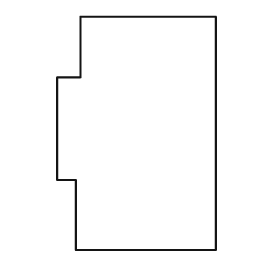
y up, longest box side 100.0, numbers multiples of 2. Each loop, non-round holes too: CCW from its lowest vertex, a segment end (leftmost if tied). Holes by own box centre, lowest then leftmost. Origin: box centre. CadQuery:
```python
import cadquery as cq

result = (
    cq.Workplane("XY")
    .moveTo(-26.0, -50.0)
    .lineTo(34.0, -50.0)
    .lineTo(34.0, 50.0)
    .lineTo(-24.0, 50.0)
    .lineTo(-24.0, 24.0)
    .lineTo(-34.0, 24.0)
    .lineTo(-34.0, -20.0)
    .lineTo(-26.0, -20.0)
    .close()
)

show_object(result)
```